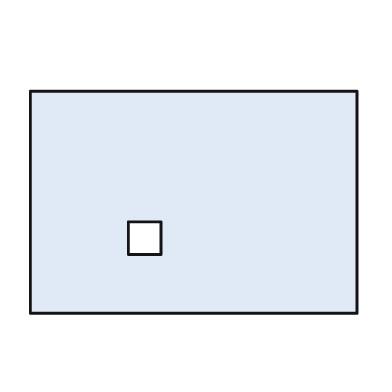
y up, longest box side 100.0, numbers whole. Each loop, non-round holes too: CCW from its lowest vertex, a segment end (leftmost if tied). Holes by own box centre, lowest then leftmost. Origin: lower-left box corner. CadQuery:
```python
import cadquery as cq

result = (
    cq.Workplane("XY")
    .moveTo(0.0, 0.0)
    .lineTo(100.0, 0.0)
    .lineTo(100.0, 68.0)
    .lineTo(0.0, 68.0)
    .close()
    .moveTo(30.0, 18.0)
    .lineTo(40.0, 18.0)
    .lineTo(40.0, 28.0)
    .lineTo(30.0, 28.0)
    .close()
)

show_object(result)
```